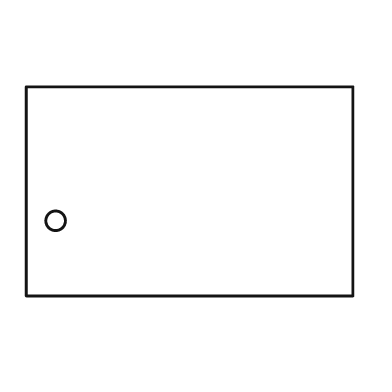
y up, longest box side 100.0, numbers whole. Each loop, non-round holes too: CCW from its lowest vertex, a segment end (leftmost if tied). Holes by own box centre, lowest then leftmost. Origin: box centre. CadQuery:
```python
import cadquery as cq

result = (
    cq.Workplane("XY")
    .moveTo(-50.0, -32.0)
    .lineTo(50.0, -32.0)
    .lineTo(50.0, 32.0)
    .lineTo(-50.0, 32.0)
    .close()
    .moveTo(-41.0, -9.0)
    .circle(3.0)
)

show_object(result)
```